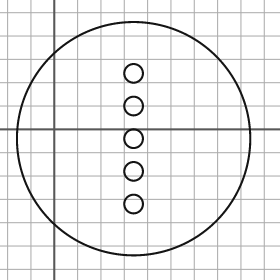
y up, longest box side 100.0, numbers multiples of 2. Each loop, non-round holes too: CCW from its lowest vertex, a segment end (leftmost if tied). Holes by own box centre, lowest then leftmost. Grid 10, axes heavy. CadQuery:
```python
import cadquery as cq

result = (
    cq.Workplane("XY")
    .moveTo(34.0, -4.0)
    .circle(50.0)
    .moveTo(34.0, -32.0)
    .circle(4.0)
    .moveTo(34.0, -18.0)
    .circle(4.0)
    .moveTo(34.0, -4.0)
    .circle(4.0)
    .moveTo(34.0, 10.0)
    .circle(4.0)
    .moveTo(34.0, 24.0)
    .circle(4.0)
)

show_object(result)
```